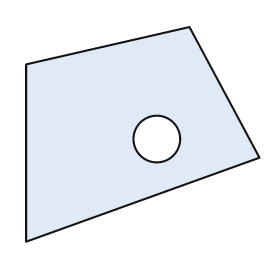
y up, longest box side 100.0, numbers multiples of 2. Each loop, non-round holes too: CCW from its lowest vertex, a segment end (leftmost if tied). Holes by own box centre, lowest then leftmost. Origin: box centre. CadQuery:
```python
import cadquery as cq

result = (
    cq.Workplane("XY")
    .moveTo(-50.0, -46.0)
    .lineTo(50.0, -10.0)
    .lineTo(20.0, 46.0)
    .lineTo(-50.0, 30.0)
    .close()
    .moveTo(6.0, -2.0)
    .circle(10.0)
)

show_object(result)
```